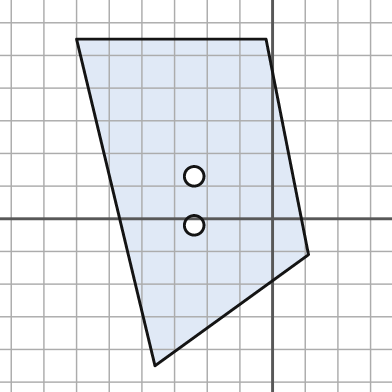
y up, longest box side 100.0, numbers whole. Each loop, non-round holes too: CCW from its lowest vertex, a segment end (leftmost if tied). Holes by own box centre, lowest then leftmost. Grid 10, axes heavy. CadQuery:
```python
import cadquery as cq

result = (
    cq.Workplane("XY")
    .moveTo(-36.0, -45.0)
    .lineTo(11.0, -11.0)
    .lineTo(-2.0, 55.0)
    .lineTo(-60.0, 55.0)
    .close()
    .moveTo(-24.0, -2.0)
    .circle(3.0)
    .moveTo(-24.0, 13.0)
    .circle(3.0)
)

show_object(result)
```